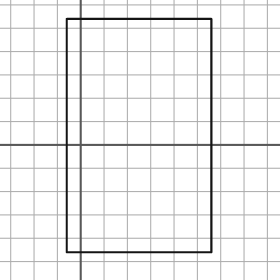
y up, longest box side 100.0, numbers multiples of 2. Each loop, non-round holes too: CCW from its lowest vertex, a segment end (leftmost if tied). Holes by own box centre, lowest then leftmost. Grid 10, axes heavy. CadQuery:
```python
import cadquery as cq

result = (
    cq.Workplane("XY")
    .moveTo(-6.0, -46.0)
    .lineTo(56.0, -46.0)
    .lineTo(56.0, 54.0)
    .lineTo(-6.0, 54.0)
    .close()
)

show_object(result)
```